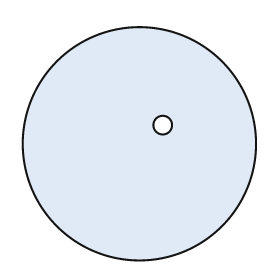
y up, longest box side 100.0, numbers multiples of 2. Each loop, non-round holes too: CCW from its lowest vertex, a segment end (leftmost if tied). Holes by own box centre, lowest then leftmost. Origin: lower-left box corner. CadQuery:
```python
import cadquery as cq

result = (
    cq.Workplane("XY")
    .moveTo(50.0, 50.0)
    .circle(50.0)
    .moveTo(60.0, 58.0)
    .circle(4.0)
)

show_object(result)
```